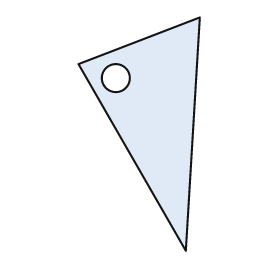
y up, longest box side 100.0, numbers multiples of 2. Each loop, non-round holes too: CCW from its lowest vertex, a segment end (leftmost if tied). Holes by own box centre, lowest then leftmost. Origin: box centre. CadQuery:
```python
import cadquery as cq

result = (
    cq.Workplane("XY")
    .moveTo(20.0, -50.0)
    .lineTo(26.0, 50.0)
    .lineTo(-26.0, 30.0)
    .close()
    .moveTo(-10.0, 24.0)
    .circle(6.0)
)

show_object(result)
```